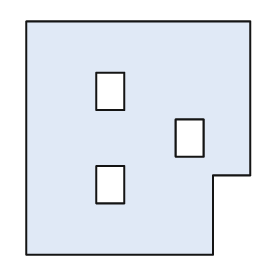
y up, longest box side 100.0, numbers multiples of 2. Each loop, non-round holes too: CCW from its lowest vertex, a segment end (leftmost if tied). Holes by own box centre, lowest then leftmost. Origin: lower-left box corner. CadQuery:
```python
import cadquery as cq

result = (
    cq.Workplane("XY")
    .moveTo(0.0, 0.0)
    .lineTo(80.0, 0.0)
    .lineTo(80.0, 34.0)
    .lineTo(96.0, 34.0)
    .lineTo(96.0, 100.0)
    .lineTo(0.0, 100.0)
    .close()
    .moveTo(30.0, 22.0)
    .lineTo(42.0, 22.0)
    .lineTo(42.0, 38.0)
    .lineTo(30.0, 38.0)
    .close()
    .moveTo(64.0, 42.0)
    .lineTo(76.0, 42.0)
    .lineTo(76.0, 58.0)
    .lineTo(64.0, 58.0)
    .close()
    .moveTo(30.0, 62.0)
    .lineTo(42.0, 62.0)
    .lineTo(42.0, 78.0)
    .lineTo(30.0, 78.0)
    .close()
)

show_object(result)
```